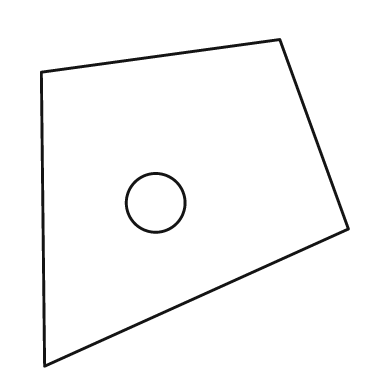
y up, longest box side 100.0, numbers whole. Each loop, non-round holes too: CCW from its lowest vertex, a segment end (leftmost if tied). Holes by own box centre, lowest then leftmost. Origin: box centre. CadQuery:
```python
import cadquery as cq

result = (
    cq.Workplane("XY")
    .moveTo(-46.0, -50.0)
    .lineTo(47.0, -8.0)
    .lineTo(26.0, 50.0)
    .lineTo(-47.0, 40.0)
    .close()
    .moveTo(-12.0, 0.0)
    .circle(9.0)
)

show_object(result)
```